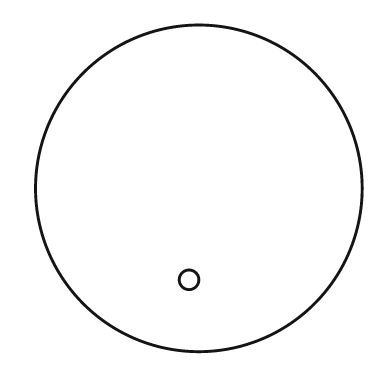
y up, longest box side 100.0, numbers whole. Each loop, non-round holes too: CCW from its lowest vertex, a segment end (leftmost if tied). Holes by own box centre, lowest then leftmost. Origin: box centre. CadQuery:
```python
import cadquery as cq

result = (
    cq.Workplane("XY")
    .moveTo(0.0, 0.0)
    .circle(50.0)
    .moveTo(-3.0, -28.0)
    .circle(3.0)
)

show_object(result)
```